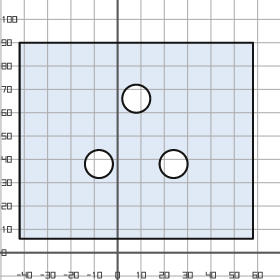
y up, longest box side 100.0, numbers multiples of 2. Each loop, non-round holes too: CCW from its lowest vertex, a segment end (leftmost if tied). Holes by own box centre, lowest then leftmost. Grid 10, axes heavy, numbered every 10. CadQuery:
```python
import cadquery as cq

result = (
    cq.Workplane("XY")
    .moveTo(-42.0, 6.0)
    .lineTo(58.0, 6.0)
    .lineTo(58.0, 90.0)
    .lineTo(-42.0, 90.0)
    .close()
    .moveTo(-8.0, 38.0)
    .circle(6.0)
    .moveTo(24.0, 38.0)
    .circle(6.0)
    .moveTo(8.0, 66.0)
    .circle(6.0)
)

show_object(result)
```